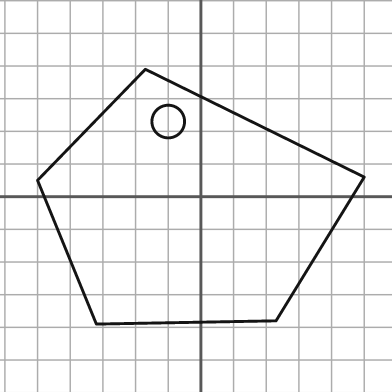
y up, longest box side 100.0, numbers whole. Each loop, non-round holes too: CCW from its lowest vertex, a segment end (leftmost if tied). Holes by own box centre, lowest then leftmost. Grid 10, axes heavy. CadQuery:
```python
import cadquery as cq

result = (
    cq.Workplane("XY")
    .moveTo(-32.0, -39.0)
    .lineTo(23.0, -38.0)
    .lineTo(50.0, 6.0)
    .lineTo(-17.0, 39.0)
    .lineTo(-50.0, 5.0)
    .close()
    .moveTo(-10.0, 23.0)
    .circle(5.0)
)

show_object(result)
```